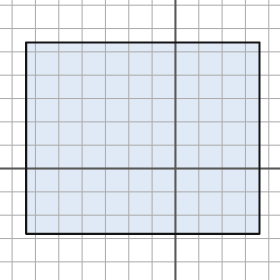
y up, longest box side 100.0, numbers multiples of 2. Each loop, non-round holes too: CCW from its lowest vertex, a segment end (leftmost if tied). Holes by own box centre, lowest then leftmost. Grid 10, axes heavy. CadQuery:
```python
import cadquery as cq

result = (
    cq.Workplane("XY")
    .moveTo(-64.0, -28.0)
    .lineTo(36.0, -28.0)
    .lineTo(36.0, 54.0)
    .lineTo(-64.0, 54.0)
    .close()
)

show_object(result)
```